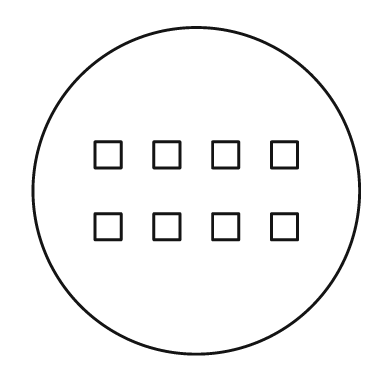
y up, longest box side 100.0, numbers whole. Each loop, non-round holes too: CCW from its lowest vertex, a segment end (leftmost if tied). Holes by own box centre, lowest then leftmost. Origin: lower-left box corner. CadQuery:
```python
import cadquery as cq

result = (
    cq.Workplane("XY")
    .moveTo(50.0, 50.0)
    .circle(50.0)
    .moveTo(19.0, 35.0)
    .lineTo(27.0, 35.0)
    .lineTo(27.0, 43.0)
    .lineTo(19.0, 43.0)
    .close()
    .moveTo(37.0, 35.0)
    .lineTo(45.0, 35.0)
    .lineTo(45.0, 43.0)
    .lineTo(37.0, 43.0)
    .close()
    .moveTo(55.0, 35.0)
    .lineTo(63.0, 35.0)
    .lineTo(63.0, 43.0)
    .lineTo(55.0, 43.0)
    .close()
    .moveTo(73.0, 35.0)
    .lineTo(81.0, 35.0)
    .lineTo(81.0, 43.0)
    .lineTo(73.0, 43.0)
    .close()
    .moveTo(19.0, 57.0)
    .lineTo(27.0, 57.0)
    .lineTo(27.0, 65.0)
    .lineTo(19.0, 65.0)
    .close()
    .moveTo(37.0, 57.0)
    .lineTo(45.0, 57.0)
    .lineTo(45.0, 65.0)
    .lineTo(37.0, 65.0)
    .close()
    .moveTo(55.0, 57.0)
    .lineTo(63.0, 57.0)
    .lineTo(63.0, 65.0)
    .lineTo(55.0, 65.0)
    .close()
    .moveTo(73.0, 57.0)
    .lineTo(81.0, 57.0)
    .lineTo(81.0, 65.0)
    .lineTo(73.0, 65.0)
    .close()
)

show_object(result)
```